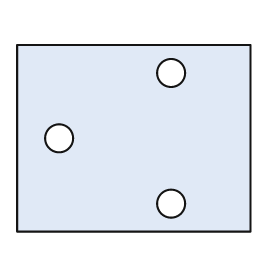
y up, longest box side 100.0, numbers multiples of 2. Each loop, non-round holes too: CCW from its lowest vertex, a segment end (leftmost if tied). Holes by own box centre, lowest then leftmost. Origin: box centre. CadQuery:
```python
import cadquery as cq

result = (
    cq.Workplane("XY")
    .moveTo(-50.0, -40.0)
    .lineTo(50.0, -40.0)
    .lineTo(50.0, 40.0)
    .lineTo(-50.0, 40.0)
    .close()
    .moveTo(16.0, -28.0)
    .circle(6.0)
    .moveTo(-32.0, 0.0)
    .circle(6.0)
    .moveTo(16.0, 28.0)
    .circle(6.0)
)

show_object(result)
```